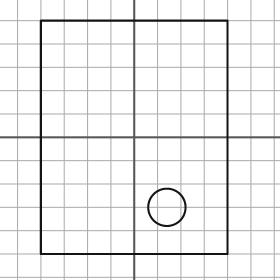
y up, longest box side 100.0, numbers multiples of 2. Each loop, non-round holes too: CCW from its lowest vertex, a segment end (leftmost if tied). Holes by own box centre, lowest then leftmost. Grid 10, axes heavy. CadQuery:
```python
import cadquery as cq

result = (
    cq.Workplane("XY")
    .moveTo(-40.0, -50.0)
    .lineTo(40.0, -50.0)
    .lineTo(40.0, 50.0)
    .lineTo(-40.0, 50.0)
    .close()
    .moveTo(14.0, -30.0)
    .circle(8.0)
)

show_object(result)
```